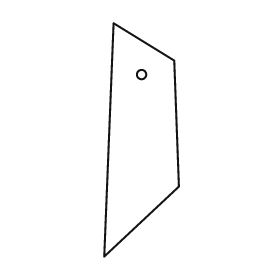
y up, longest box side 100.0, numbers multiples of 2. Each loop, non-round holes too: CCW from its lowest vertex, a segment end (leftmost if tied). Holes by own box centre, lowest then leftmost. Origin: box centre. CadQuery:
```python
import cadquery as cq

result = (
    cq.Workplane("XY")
    .moveTo(-16.0, -50.0)
    .lineTo(16.0, -20.0)
    .lineTo(14.0, 34.0)
    .lineTo(-12.0, 50.0)
    .close()
    .moveTo(0.0, 28.0)
    .circle(2.0)
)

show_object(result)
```